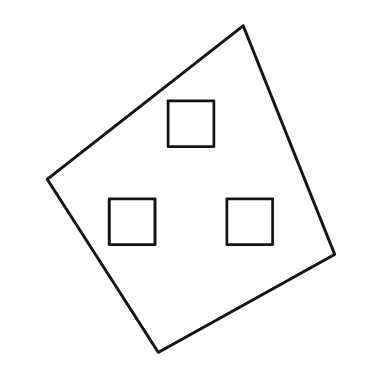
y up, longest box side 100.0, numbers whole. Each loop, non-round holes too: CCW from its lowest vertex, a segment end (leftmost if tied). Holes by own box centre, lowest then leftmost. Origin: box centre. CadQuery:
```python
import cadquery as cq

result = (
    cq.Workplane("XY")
    .moveTo(-10.0, -50.0)
    .lineTo(44.0, -20.0)
    .lineTo(16.0, 50.0)
    .lineTo(-44.0, 3.0)
    .close()
    .moveTo(-25.0, -17.0)
    .lineTo(-11.0, -17.0)
    .lineTo(-11.0, -3.0)
    .lineTo(-25.0, -3.0)
    .close()
    .moveTo(11.0, -17.0)
    .lineTo(25.0, -17.0)
    .lineTo(25.0, -3.0)
    .lineTo(11.0, -3.0)
    .close()
    .moveTo(-7.0, 13.0)
    .lineTo(7.0, 13.0)
    .lineTo(7.0, 27.0)
    .lineTo(-7.0, 27.0)
    .close()
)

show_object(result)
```